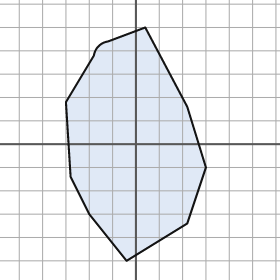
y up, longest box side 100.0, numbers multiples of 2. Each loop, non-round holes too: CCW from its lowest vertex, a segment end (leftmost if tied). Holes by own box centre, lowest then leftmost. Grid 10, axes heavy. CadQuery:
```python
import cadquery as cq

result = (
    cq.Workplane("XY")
    .moveTo(-4.0, -50.0)
    .lineTo(22.0, -34.0)
    .lineTo(30.0, -10.0)
    .lineTo(22.0, 16.0)
    .lineTo(4.0, 50.0)
    .lineTo(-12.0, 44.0)
    .threePointArc((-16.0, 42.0), (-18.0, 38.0))
    .lineTo(-30.0, 18.0)
    .lineTo(-28.0, -14.0)
    .lineTo(-20.0, -30.0)
    .close()
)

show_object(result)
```